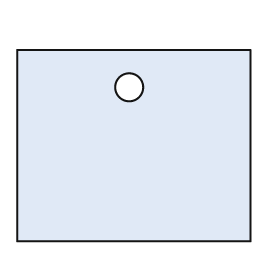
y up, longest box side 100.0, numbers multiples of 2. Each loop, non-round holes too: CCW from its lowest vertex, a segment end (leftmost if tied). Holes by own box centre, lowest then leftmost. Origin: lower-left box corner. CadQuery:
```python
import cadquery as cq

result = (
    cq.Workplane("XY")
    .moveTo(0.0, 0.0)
    .lineTo(100.0, 0.0)
    .lineTo(100.0, 82.0)
    .lineTo(0.0, 82.0)
    .close()
    .moveTo(48.0, 66.0)
    .circle(6.0)
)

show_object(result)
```